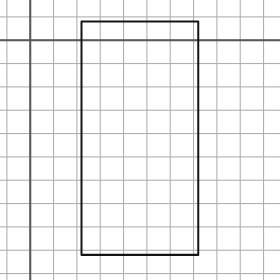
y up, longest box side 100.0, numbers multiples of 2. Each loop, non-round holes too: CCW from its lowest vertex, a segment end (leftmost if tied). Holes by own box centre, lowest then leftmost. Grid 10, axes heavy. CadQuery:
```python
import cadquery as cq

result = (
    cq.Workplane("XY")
    .moveTo(22.0, -92.0)
    .lineTo(72.0, -92.0)
    .lineTo(72.0, 8.0)
    .lineTo(22.0, 8.0)
    .close()
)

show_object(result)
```